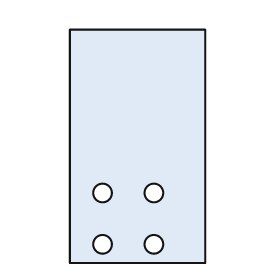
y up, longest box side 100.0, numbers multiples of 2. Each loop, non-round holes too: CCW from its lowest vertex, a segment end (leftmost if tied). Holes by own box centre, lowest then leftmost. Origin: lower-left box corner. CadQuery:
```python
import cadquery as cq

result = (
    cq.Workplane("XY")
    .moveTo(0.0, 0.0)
    .lineTo(58.0, 0.0)
    .lineTo(58.0, 100.0)
    .lineTo(0.0, 100.0)
    .close()
    .moveTo(14.0, 8.0)
    .circle(4.0)
    .moveTo(36.0, 8.0)
    .circle(4.0)
    .moveTo(14.0, 30.0)
    .circle(4.0)
    .moveTo(36.0, 30.0)
    .circle(4.0)
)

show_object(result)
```